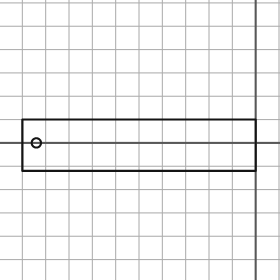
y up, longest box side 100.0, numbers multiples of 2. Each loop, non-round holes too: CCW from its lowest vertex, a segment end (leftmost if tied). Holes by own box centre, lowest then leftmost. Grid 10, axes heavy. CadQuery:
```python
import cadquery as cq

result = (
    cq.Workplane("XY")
    .moveTo(-100.0, -12.0)
    .lineTo(0.0, -12.0)
    .lineTo(0.0, 10.0)
    .lineTo(-100.0, 10.0)
    .close()
    .moveTo(-94.0, 0.0)
    .circle(2.0)
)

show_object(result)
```